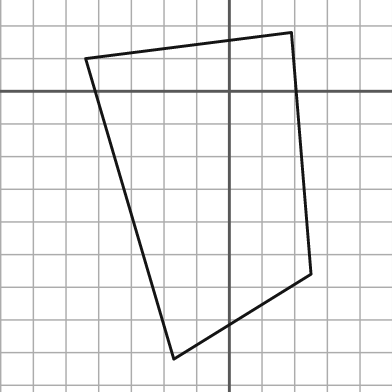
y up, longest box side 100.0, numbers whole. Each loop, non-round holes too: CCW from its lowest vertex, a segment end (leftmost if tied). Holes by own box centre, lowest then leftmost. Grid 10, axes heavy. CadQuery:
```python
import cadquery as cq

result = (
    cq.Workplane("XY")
    .moveTo(-17.0, -82.0)
    .lineTo(25.0, -56.0)
    .lineTo(19.0, 18.0)
    .lineTo(-44.0, 10.0)
    .close()
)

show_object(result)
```